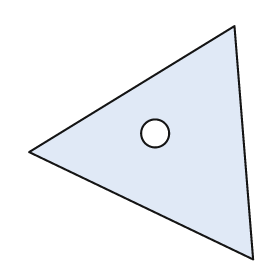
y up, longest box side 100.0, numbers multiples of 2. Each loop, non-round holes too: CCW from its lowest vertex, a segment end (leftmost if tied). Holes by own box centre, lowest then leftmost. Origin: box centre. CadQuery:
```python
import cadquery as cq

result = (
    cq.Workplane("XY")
    .moveTo(48.0, -50.0)
    .lineTo(40.0, 50.0)
    .lineTo(-48.0, -4.0)
    .close()
    .moveTo(6.0, 4.0)
    .circle(6.0)
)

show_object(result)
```